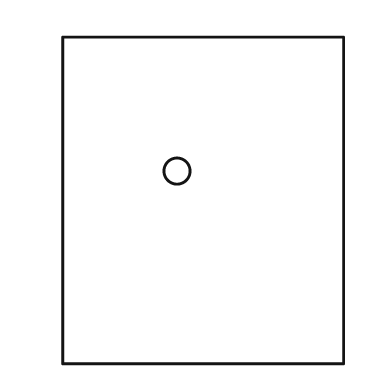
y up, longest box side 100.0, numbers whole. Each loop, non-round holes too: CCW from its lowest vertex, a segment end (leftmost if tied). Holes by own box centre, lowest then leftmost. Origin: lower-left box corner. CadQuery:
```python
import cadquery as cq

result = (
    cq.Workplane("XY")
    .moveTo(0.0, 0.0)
    .lineTo(86.0, 0.0)
    .lineTo(86.0, 100.0)
    .lineTo(0.0, 100.0)
    .close()
    .moveTo(35.0, 59.0)
    .circle(4.0)
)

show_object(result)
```